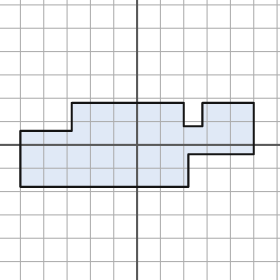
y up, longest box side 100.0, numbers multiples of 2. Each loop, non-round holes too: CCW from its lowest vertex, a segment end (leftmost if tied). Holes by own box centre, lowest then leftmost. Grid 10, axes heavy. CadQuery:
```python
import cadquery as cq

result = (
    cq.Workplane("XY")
    .moveTo(-50.0, -18.0)
    .lineTo(22.0, -18.0)
    .lineTo(22.0, -4.0)
    .lineTo(50.0, -4.0)
    .lineTo(50.0, 18.0)
    .lineTo(28.0, 18.0)
    .lineTo(28.0, 8.0)
    .lineTo(20.0, 8.0)
    .lineTo(20.0, 18.0)
    .lineTo(-28.0, 18.0)
    .lineTo(-28.0, 6.0)
    .lineTo(-50.0, 6.0)
    .close()
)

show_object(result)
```